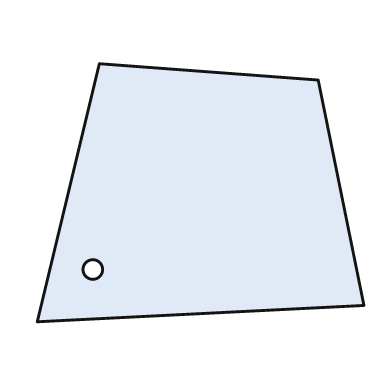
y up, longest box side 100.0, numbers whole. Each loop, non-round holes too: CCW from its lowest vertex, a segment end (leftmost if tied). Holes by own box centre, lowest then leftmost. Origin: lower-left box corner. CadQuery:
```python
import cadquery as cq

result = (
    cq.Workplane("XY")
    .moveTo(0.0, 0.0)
    .lineTo(100.0, 5.0)
    .lineTo(86.0, 74.0)
    .lineTo(19.0, 79.0)
    .close()
    .moveTo(17.0, 16.0)
    .circle(3.0)
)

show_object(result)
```